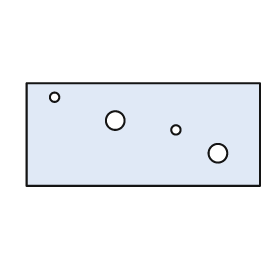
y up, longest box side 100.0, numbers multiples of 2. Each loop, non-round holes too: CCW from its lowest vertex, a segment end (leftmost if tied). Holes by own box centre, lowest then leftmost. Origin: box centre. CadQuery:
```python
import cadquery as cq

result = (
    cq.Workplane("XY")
    .moveTo(-50.0, -22.0)
    .lineTo(50.0, -22.0)
    .lineTo(50.0, 22.0)
    .lineTo(-50.0, 22.0)
    .close()
    .moveTo(32.0, -8.0)
    .circle(4.0)
    .moveTo(14.0, 2.0)
    .circle(2.0)
    .moveTo(-12.0, 6.0)
    .circle(4.0)
    .moveTo(-38.0, 16.0)
    .circle(2.0)
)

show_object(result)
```